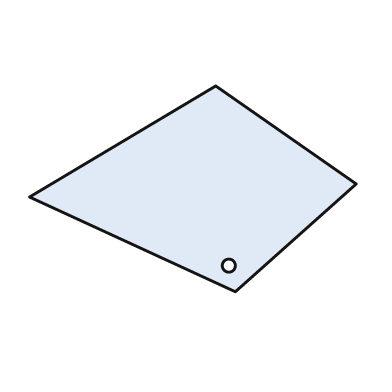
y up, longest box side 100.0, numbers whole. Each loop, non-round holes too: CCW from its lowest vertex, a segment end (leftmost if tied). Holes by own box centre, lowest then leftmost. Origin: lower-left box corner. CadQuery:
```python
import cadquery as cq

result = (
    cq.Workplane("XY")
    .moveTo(63.0, 0.0)
    .lineTo(100.0, 33.0)
    .lineTo(57.0, 63.0)
    .lineTo(0.0, 29.0)
    .close()
    .moveTo(61.0, 8.0)
    .circle(2.0)
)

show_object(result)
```